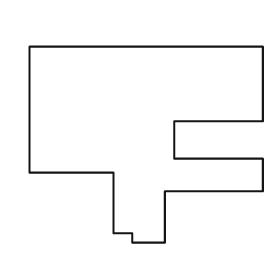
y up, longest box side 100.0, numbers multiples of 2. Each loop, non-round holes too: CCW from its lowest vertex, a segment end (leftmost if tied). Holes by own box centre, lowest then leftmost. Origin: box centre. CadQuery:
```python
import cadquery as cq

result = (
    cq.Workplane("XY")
    .moveTo(-6.0, -42.0)
    .lineTo(8.0, -42.0)
    .lineTo(8.0, -20.0)
    .lineTo(50.0, -20.0)
    .lineTo(50.0, -6.0)
    .lineTo(12.0, -6.0)
    .lineTo(12.0, 10.0)
    .lineTo(50.0, 10.0)
    .lineTo(50.0, 42.0)
    .lineTo(-50.0, 42.0)
    .lineTo(-50.0, -12.0)
    .lineTo(-14.0, -12.0)
    .lineTo(-14.0, -38.0)
    .lineTo(-6.0, -38.0)
    .close()
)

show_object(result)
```